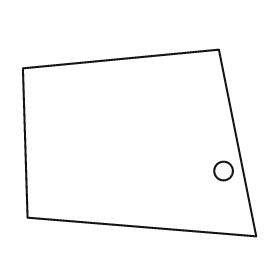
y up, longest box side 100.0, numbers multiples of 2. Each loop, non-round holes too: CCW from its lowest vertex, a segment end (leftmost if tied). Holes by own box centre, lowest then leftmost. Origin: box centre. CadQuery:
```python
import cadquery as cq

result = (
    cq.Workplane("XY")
    .moveTo(50.0, -40.0)
    .lineTo(34.0, 40.0)
    .lineTo(-50.0, 32.0)
    .lineTo(-48.0, -32.0)
    .close()
    .moveTo(36.0, -12.0)
    .circle(4.0)
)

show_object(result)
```